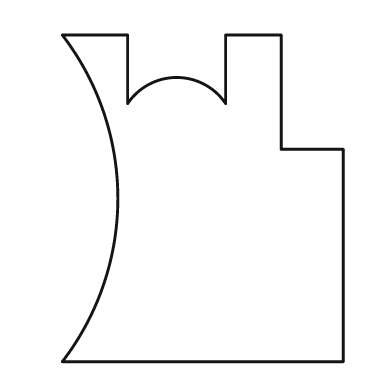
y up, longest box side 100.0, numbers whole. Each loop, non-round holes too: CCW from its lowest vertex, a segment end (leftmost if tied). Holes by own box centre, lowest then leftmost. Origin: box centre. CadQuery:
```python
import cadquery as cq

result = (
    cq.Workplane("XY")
    .moveTo(-43.0, -50.0)
    .lineTo(43.0, -50.0)
    .lineTo(43.0, 15.0)
    .lineTo(24.0, 15.0)
    .lineTo(24.0, 50.0)
    .lineTo(7.0, 50.0)
    .lineTo(7.0, 29.0)
    .threePointArc((-8.0, 37.0), (-23.0, 29.0))
    .lineTo(-23.0, 50.0)
    .lineTo(-43.0, 50.0)
    .threePointArc((-26.0, 0.0), (-43.0, -50.0))
    .close()
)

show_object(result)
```